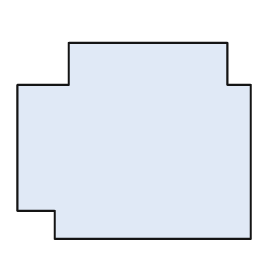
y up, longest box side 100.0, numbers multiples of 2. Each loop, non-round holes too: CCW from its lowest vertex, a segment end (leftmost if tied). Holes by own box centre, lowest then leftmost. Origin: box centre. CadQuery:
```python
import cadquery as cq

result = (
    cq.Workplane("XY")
    .moveTo(-34.0, -42.0)
    .lineTo(50.0, -42.0)
    .lineTo(50.0, 24.0)
    .lineTo(40.0, 24.0)
    .lineTo(40.0, 42.0)
    .lineTo(-28.0, 42.0)
    .lineTo(-28.0, 24.0)
    .lineTo(-50.0, 24.0)
    .lineTo(-50.0, -30.0)
    .lineTo(-34.0, -30.0)
    .close()
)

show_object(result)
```